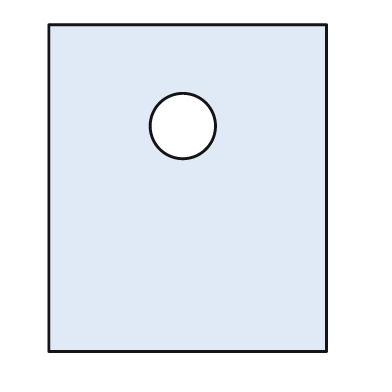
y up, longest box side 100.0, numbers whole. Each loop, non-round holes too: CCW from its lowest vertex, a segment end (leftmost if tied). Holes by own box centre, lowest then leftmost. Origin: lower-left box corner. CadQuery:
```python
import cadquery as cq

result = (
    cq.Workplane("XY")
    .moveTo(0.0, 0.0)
    .lineTo(85.0, 0.0)
    .lineTo(85.0, 100.0)
    .lineTo(0.0, 100.0)
    .close()
    .moveTo(41.0, 69.0)
    .circle(10.0)
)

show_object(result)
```